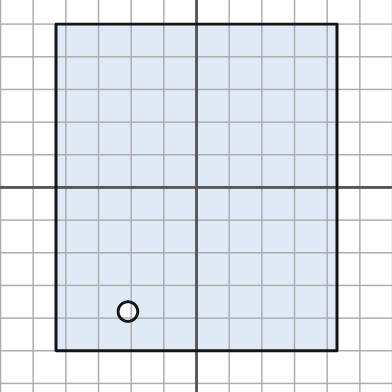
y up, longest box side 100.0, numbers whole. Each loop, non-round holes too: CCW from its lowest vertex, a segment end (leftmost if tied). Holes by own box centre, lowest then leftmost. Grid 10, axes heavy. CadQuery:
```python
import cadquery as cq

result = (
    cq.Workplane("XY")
    .moveTo(-43.0, -50.0)
    .lineTo(43.0, -50.0)
    .lineTo(43.0, 50.0)
    .lineTo(-43.0, 50.0)
    .close()
    .moveTo(-21.0, -38.0)
    .circle(3.0)
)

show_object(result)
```